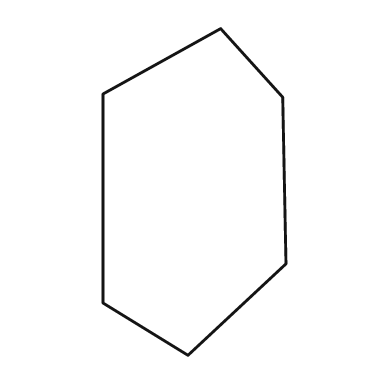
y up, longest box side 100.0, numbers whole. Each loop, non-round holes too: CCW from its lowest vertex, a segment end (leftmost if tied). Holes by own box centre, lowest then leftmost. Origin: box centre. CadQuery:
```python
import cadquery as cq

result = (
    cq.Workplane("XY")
    .moveTo(-2.0, -50.0)
    .lineTo(28.0, -22.0)
    .lineTo(27.0, 29.0)
    .lineTo(8.0, 50.0)
    .lineTo(-28.0, 30.0)
    .lineTo(-28.0, -34.0)
    .close()
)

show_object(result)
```